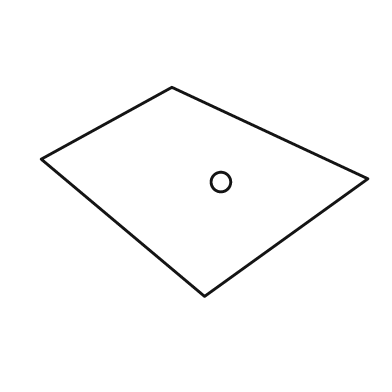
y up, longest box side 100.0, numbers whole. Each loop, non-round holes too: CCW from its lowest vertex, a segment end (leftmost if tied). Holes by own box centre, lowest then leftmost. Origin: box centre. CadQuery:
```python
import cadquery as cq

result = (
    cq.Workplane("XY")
    .moveTo(0.0, -32.0)
    .lineTo(50.0, 4.0)
    .lineTo(-10.0, 32.0)
    .lineTo(-50.0, 10.0)
    .close()
    .moveTo(5.0, 3.0)
    .circle(3.0)
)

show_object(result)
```